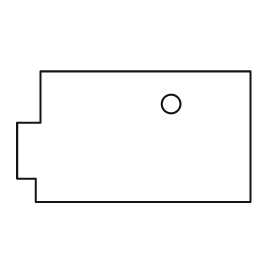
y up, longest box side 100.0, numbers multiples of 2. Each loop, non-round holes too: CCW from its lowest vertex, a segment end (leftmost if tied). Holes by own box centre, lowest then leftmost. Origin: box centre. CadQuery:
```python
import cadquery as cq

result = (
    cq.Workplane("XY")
    .moveTo(-42.0, -28.0)
    .lineTo(50.0, -28.0)
    .lineTo(50.0, 28.0)
    .lineTo(-40.0, 28.0)
    .lineTo(-40.0, 6.0)
    .lineTo(-50.0, 6.0)
    .lineTo(-50.0, -18.0)
    .lineTo(-42.0, -18.0)
    .close()
    .moveTo(16.0, 14.0)
    .circle(4.0)
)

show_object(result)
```